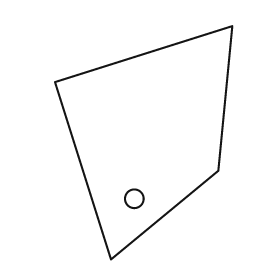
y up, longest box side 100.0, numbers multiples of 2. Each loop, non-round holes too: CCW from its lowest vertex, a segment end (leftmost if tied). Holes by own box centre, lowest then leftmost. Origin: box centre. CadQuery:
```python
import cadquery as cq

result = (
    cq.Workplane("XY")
    .moveTo(-14.0, -50.0)
    .lineTo(32.0, -12.0)
    .lineTo(38.0, 50.0)
    .lineTo(-38.0, 26.0)
    .close()
    .moveTo(-4.0, -24.0)
    .circle(4.0)
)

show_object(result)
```